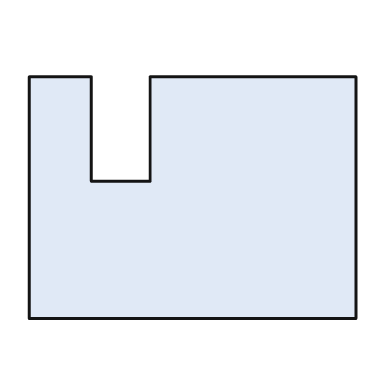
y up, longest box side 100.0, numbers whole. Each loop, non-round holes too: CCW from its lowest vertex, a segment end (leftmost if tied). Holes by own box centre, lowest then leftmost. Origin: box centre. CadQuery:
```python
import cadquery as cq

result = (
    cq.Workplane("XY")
    .moveTo(-50.0, -37.0)
    .lineTo(50.0, -37.0)
    .lineTo(50.0, 37.0)
    .lineTo(-13.0, 37.0)
    .lineTo(-13.0, 5.0)
    .lineTo(-31.0, 5.0)
    .lineTo(-31.0, 37.0)
    .lineTo(-50.0, 37.0)
    .close()
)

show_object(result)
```